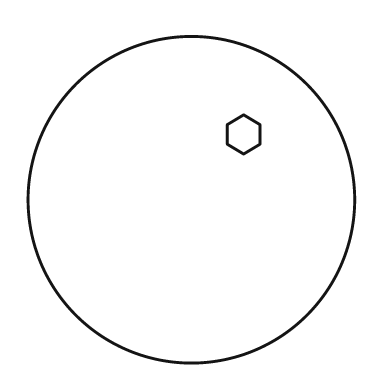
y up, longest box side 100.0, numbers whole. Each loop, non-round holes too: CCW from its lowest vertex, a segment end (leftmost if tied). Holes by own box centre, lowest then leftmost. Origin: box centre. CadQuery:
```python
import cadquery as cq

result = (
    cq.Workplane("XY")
    .moveTo(0.0, 0.0)
    .circle(50.0)
    .moveTo(16.0, 14.0)
    .lineTo(21.0, 17.0)
    .lineTo(21.0, 23.0)
    .lineTo(16.0, 26.0)
    .lineTo(11.0, 23.0)
    .lineTo(11.0, 17.0)
    .close()
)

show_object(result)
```